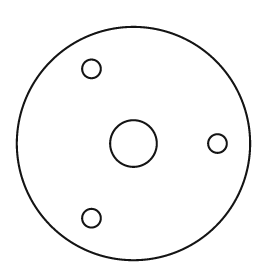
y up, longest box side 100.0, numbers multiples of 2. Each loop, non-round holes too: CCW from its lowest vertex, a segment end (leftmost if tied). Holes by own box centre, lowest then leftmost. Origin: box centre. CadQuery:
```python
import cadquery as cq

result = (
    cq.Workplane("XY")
    .moveTo(0.0, 0.0)
    .circle(50.0)
    .moveTo(-18.0, -32.0)
    .circle(4.0)
    .moveTo(0.0, 0.0)
    .circle(10.0)
    .moveTo(36.0, 0.0)
    .circle(4.0)
    .moveTo(-18.0, 32.0)
    .circle(4.0)
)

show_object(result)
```